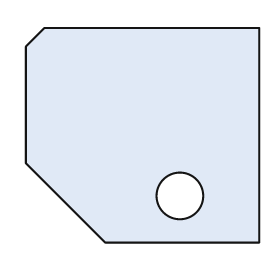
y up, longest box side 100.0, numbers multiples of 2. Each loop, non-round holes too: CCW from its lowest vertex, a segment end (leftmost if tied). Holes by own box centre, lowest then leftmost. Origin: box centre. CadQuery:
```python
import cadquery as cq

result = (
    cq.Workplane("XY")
    .moveTo(-16.0, -46.0)
    .lineTo(50.0, -46.0)
    .lineTo(50.0, 46.0)
    .lineTo(-42.0, 46.0)
    .lineTo(-50.0, 38.0)
    .lineTo(-50.0, -12.0)
    .close()
    .moveTo(16.0, -26.0)
    .circle(10.0)
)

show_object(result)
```